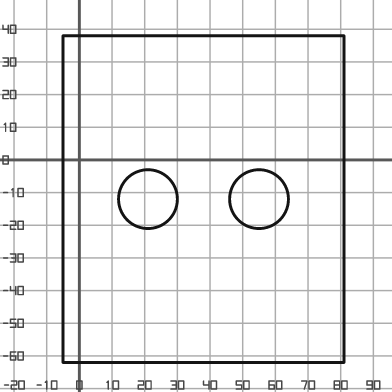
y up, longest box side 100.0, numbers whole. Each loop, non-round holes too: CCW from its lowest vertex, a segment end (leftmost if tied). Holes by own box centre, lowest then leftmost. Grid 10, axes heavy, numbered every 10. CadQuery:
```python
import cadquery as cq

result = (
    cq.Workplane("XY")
    .moveTo(-5.0, -62.0)
    .lineTo(81.0, -62.0)
    .lineTo(81.0, 38.0)
    .lineTo(-5.0, 38.0)
    .close()
    .moveTo(21.0, -12.0)
    .circle(9.0)
    .moveTo(55.0, -12.0)
    .circle(9.0)
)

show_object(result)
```